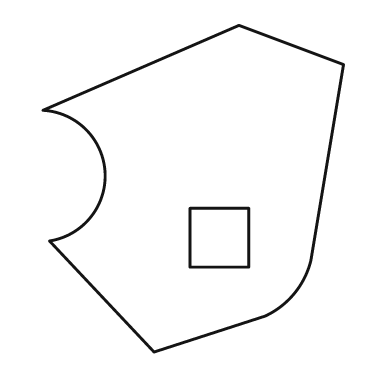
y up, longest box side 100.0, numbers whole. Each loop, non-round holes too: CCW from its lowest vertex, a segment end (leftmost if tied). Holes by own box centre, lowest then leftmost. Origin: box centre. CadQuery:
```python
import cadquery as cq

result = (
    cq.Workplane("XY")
    .moveTo(-12.0, -50.0)
    .lineTo(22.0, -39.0)
    .threePointArc((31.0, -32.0), (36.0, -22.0))
    .lineTo(46.0, 38.0)
    .lineTo(14.0, 50.0)
    .lineTo(-46.0, 24.0)
    .threePointArc((-27.0, 5.0), (-44.0, -16.0))
    .close()
    .moveTo(-1.0, -24.0)
    .lineTo(17.0, -24.0)
    .lineTo(17.0, -6.0)
    .lineTo(-1.0, -6.0)
    .close()
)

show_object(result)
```